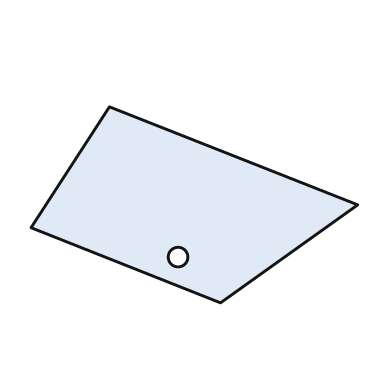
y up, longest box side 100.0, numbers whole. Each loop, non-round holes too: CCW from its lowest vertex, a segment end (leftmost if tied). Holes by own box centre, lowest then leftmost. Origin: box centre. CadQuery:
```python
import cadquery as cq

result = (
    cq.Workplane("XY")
    .moveTo(8.0, -30.0)
    .lineTo(50.0, 0.0)
    .lineTo(-26.0, 30.0)
    .lineTo(-50.0, -7.0)
    .close()
    .moveTo(-5.0, -16.0)
    .circle(3.0)
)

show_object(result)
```